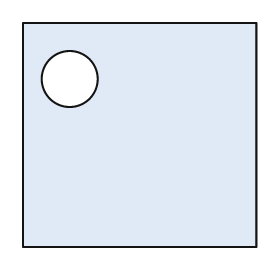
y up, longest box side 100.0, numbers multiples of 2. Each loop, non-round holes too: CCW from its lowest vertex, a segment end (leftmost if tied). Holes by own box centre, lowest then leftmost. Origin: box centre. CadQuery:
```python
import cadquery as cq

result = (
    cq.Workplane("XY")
    .moveTo(-50.0, -48.0)
    .lineTo(50.0, -48.0)
    .lineTo(50.0, 48.0)
    .lineTo(-50.0, 48.0)
    .close()
    .moveTo(-30.0, 24.0)
    .circle(12.0)
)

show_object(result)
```